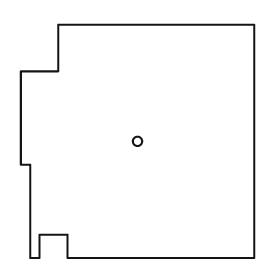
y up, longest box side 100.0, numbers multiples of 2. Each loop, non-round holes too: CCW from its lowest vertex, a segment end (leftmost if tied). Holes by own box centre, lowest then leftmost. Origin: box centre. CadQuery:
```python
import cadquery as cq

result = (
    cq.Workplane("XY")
    .moveTo(-46.0, -50.0)
    .lineTo(-42.0, -50.0)
    .lineTo(-42.0, -40.0)
    .lineTo(-30.0, -40.0)
    .lineTo(-30.0, -50.0)
    .lineTo(50.0, -50.0)
    .lineTo(50.0, 50.0)
    .lineTo(-34.0, 50.0)
    .lineTo(-34.0, 30.0)
    .lineTo(-50.0, 30.0)
    .lineTo(-50.0, -10.0)
    .lineTo(-46.0, -10.0)
    .close()
    .moveTo(0.0, 0.0)
    .circle(2.0)
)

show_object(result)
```